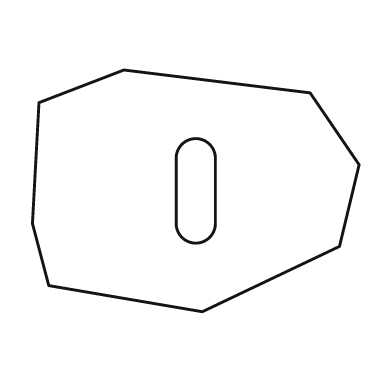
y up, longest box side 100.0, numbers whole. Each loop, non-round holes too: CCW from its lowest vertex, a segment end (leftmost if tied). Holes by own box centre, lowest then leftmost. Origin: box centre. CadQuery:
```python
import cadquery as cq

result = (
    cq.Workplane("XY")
    .moveTo(2.0, -37.0)
    .lineTo(44.0, -17.0)
    .lineTo(50.0, 8.0)
    .lineTo(35.0, 30.0)
    .lineTo(-22.0, 37.0)
    .lineTo(-48.0, 27.0)
    .lineTo(-50.0, -10.0)
    .lineTo(-45.0, -29.0)
    .close()
    .moveTo(-6.0, -10.0)
    .threePointArc((0.0, -16.0), (6.0, -10.0))
    .lineTo(6.0, 10.0)
    .threePointArc((0.0, 16.0), (-6.0, 10.0))
    .close()
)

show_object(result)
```